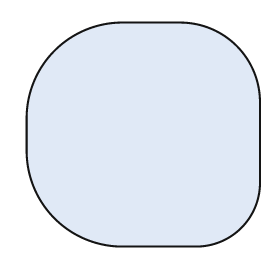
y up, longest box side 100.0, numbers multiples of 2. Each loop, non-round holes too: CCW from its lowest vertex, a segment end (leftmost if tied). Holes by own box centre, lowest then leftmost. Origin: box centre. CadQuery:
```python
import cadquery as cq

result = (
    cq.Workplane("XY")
    .moveTo(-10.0, -48.0)
    .lineTo(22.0, -48.0)
    .threePointArc((42.0, -40.0), (50.0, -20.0))
    .lineTo(50.0, 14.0)
    .threePointArc((40.0, 38.0), (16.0, 48.0))
    .lineTo(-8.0, 48.0)
    .threePointArc((-38.0, 36.0), (-50.0, 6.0))
    .lineTo(-50.0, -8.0)
    .threePointArc((-38.0, -36.0), (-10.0, -48.0))
    .close()
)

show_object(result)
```